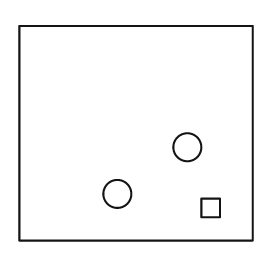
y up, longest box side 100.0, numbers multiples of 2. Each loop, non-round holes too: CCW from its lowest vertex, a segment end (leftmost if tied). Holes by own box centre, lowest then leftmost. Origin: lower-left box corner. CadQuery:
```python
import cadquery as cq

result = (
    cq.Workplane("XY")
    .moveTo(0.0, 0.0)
    .lineTo(100.0, 0.0)
    .lineTo(100.0, 92.0)
    .lineTo(0.0, 92.0)
    .close()
    .moveTo(78.0, 10.0)
    .lineTo(86.0, 10.0)
    .lineTo(86.0, 18.0)
    .lineTo(78.0, 18.0)
    .close()
    .moveTo(42.0, 20.0)
    .circle(6.0)
    .moveTo(72.0, 40.0)
    .circle(6.0)
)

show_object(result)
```